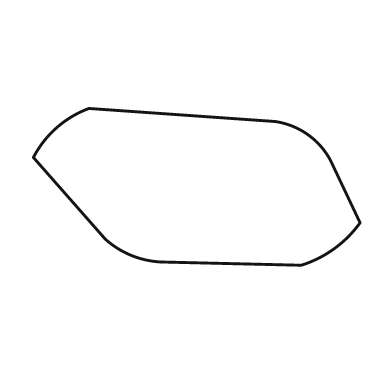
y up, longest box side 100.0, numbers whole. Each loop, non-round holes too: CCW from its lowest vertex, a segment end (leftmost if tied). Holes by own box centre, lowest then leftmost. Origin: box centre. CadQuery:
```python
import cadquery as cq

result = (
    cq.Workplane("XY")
    .moveTo(32.0, -24.0)
    .threePointArc((42.0, -19.0), (50.0, -11.0))
    .lineTo(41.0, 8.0)
    .threePointArc((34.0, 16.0), (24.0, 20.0))
    .lineTo(-33.0, 24.0)
    .threePointArc((-43.0, 18.0), (-50.0, 9.0))
    .lineTo(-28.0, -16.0)
    .threePointArc((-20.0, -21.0), (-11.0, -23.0))
    .close()
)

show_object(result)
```